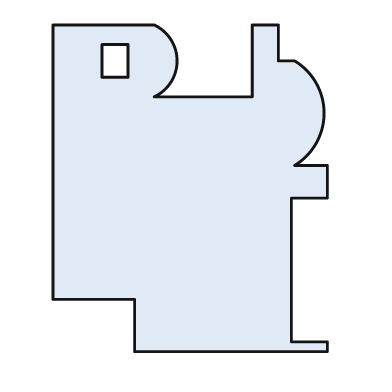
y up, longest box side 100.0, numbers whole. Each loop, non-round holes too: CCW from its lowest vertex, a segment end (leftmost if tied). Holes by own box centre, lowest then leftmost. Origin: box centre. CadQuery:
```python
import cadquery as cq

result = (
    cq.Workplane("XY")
    .moveTo(-17.0, -50.0)
    .lineTo(42.0, -50.0)
    .lineTo(42.0, -47.0)
    .lineTo(31.0, -47.0)
    .lineTo(31.0, -3.0)
    .lineTo(42.0, -3.0)
    .lineTo(42.0, 7.0)
    .lineTo(32.0, 7.0)
    .threePointArc((41.0, 23.0), (32.0, 39.0))
    .lineTo(27.0, 39.0)
    .lineTo(27.0, 50.0)
    .lineTo(19.0, 50.0)
    .lineTo(19.0, 28.0)
    .lineTo(-11.0, 28.0)
    .threePointArc((-4.0, 39.0), (-11.0, 50.0))
    .lineTo(-42.0, 50.0)
    .lineTo(-42.0, -34.0)
    .lineTo(-17.0, -34.0)
    .close()
    .moveTo(-27.0, 34.0)
    .lineTo(-19.0, 34.0)
    .lineTo(-19.0, 44.0)
    .lineTo(-27.0, 44.0)
    .close()
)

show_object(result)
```